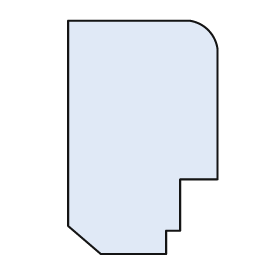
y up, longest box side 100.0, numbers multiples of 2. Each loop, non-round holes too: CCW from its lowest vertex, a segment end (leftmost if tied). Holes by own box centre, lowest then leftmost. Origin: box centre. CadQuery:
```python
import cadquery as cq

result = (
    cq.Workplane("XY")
    .moveTo(-18.0, -50.0)
    .lineTo(10.0, -50.0)
    .lineTo(10.0, -40.0)
    .lineTo(16.0, -40.0)
    .lineTo(16.0, -18.0)
    .lineTo(32.0, -18.0)
    .lineTo(32.0, 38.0)
    .threePointArc((28.0, 46.0), (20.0, 50.0))
    .lineTo(-32.0, 50.0)
    .lineTo(-32.0, -38.0)
    .close()
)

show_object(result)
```